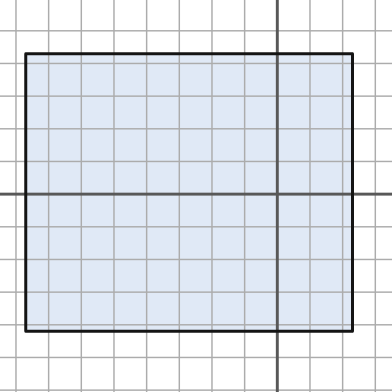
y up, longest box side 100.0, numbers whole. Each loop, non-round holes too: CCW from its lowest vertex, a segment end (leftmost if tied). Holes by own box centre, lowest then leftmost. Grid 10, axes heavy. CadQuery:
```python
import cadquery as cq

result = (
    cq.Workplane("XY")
    .moveTo(-77.0, -42.0)
    .lineTo(23.0, -42.0)
    .lineTo(23.0, 43.0)
    .lineTo(-77.0, 43.0)
    .close()
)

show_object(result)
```